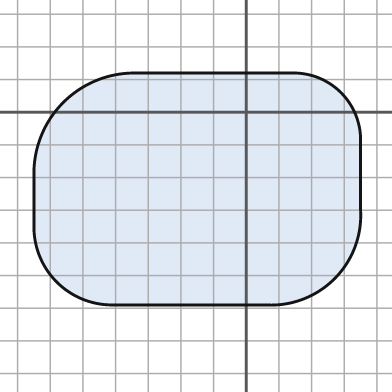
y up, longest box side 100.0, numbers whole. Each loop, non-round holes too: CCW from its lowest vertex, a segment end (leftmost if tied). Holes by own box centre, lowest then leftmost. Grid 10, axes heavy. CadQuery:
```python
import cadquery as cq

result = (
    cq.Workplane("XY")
    .moveTo(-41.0, -59.0)
    .lineTo(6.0, -59.0)
    .threePointArc((27.0, -51.0), (35.0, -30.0))
    .lineTo(35.0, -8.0)
    .threePointArc((29.0, 6.0), (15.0, 12.0))
    .lineTo(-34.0, 12.0)
    .threePointArc((-56.0, 3.0), (-65.0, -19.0))
    .lineTo(-65.0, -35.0)
    .threePointArc((-58.0, -52.0), (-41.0, -59.0))
    .close()
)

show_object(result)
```